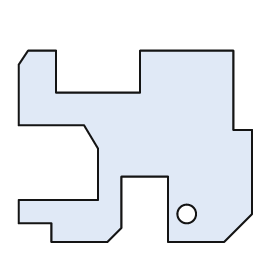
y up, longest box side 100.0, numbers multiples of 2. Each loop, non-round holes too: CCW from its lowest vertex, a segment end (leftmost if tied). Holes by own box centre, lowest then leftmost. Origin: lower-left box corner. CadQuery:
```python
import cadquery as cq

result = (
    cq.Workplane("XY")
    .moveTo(14.0, 0.0)
    .lineTo(38.0, 0.0)
    .lineTo(44.0, 6.0)
    .lineTo(44.0, 28.0)
    .lineTo(64.0, 28.0)
    .lineTo(64.0, 0.0)
    .lineTo(88.0, 0.0)
    .lineTo(100.0, 12.0)
    .lineTo(100.0, 48.0)
    .lineTo(92.0, 48.0)
    .lineTo(92.0, 82.0)
    .lineTo(52.0, 82.0)
    .lineTo(52.0, 64.0)
    .lineTo(16.0, 64.0)
    .lineTo(16.0, 82.0)
    .lineTo(4.0, 82.0)
    .lineTo(0.0, 76.0)
    .lineTo(0.0, 50.0)
    .lineTo(28.0, 50.0)
    .lineTo(34.0, 40.0)
    .lineTo(34.0, 18.0)
    .lineTo(0.0, 18.0)
    .lineTo(0.0, 8.0)
    .lineTo(14.0, 8.0)
    .close()
    .moveTo(72.0, 12.0)
    .circle(4.0)
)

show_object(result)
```